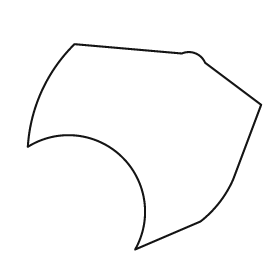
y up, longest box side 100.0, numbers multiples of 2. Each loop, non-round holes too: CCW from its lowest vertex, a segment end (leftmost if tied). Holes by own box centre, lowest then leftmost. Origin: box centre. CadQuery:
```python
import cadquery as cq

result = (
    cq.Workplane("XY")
    .moveTo(-4.0, -44.0)
    .lineTo(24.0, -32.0)
    .threePointArc((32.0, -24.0), (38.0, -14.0))
    .lineTo(50.0, 18.0)
    .lineTo(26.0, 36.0)
    .threePointArc((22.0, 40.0), (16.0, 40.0))
    .lineTo(-30.0, 44.0)
    .threePointArc((-44.0, 24.0), (-50.0, 0.0))
    .threePointArc((-10.0, -4.0), (-4.0, -44.0))
    .close()
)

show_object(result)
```